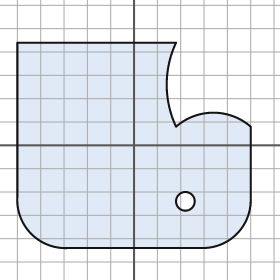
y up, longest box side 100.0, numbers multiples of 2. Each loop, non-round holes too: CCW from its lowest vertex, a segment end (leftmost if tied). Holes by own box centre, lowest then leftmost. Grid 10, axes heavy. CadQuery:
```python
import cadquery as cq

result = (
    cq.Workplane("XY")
    .moveTo(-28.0, -44.0)
    .lineTo(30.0, -44.0)
    .threePointArc((44.0, -38.0), (50.0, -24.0))
    .lineTo(50.0, 8.0)
    .threePointArc((34.0, 14.0), (18.0, 8.0))
    .threePointArc((14.0, 26.0), (18.0, 44.0))
    .lineTo(-50.0, 44.0)
    .lineTo(-50.0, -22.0)
    .threePointArc((-44.0, -38.0), (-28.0, -44.0))
    .close()
    .moveTo(22.0, -24.0)
    .circle(4.0)
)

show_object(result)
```